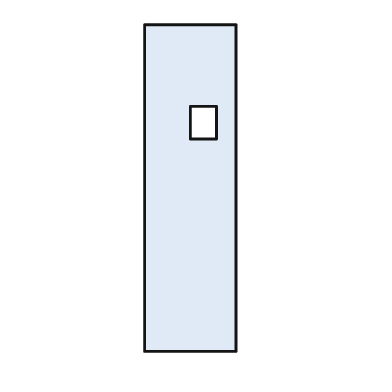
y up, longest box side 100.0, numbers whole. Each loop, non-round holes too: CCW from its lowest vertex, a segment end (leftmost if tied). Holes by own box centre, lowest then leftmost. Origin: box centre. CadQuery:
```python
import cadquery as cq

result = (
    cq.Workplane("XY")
    .moveTo(-14.0, -50.0)
    .lineTo(14.0, -50.0)
    .lineTo(14.0, 50.0)
    .lineTo(-14.0, 50.0)
    .close()
    .moveTo(0.0, 15.0)
    .lineTo(8.0, 15.0)
    .lineTo(8.0, 25.0)
    .lineTo(0.0, 25.0)
    .close()
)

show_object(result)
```